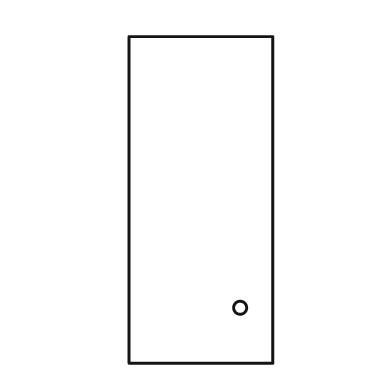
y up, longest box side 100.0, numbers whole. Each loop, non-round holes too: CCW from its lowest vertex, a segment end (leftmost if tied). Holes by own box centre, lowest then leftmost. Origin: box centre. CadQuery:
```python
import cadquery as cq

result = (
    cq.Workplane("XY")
    .moveTo(-22.0, -50.0)
    .lineTo(22.0, -50.0)
    .lineTo(22.0, 50.0)
    .lineTo(-22.0, 50.0)
    .close()
    .moveTo(12.0, -33.0)
    .circle(2.0)
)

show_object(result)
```